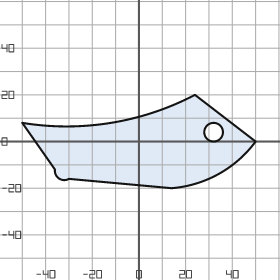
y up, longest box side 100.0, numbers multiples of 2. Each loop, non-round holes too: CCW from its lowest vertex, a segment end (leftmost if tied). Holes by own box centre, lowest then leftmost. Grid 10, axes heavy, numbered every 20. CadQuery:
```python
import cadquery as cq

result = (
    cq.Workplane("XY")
    .moveTo(14.0, -20.0)
    .threePointArc((34.0, -14.0), (50.0, 0.0))
    .lineTo(24.0, 20.0)
    .threePointArc((-12.0, 8.0), (-50.0, 8.0))
    .lineTo(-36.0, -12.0)
    .threePointArc((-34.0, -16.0), (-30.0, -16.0))
    .close()
    .moveTo(32.0, 4.0)
    .circle(4.0)
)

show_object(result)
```